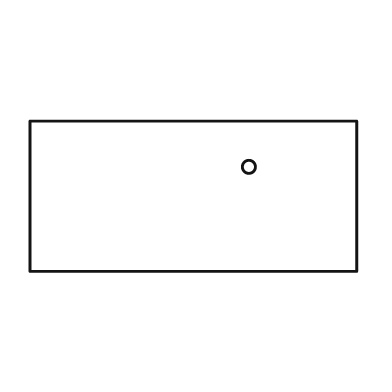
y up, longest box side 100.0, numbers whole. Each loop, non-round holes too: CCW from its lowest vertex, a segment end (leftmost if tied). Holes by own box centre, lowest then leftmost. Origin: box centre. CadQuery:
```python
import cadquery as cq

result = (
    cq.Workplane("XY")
    .moveTo(-50.0, -23.0)
    .lineTo(50.0, -23.0)
    .lineTo(50.0, 23.0)
    .lineTo(-50.0, 23.0)
    .close()
    .moveTo(17.0, 9.0)
    .circle(2.0)
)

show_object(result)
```